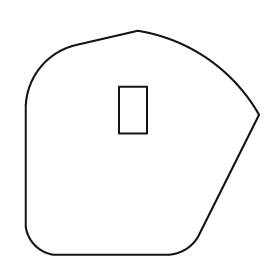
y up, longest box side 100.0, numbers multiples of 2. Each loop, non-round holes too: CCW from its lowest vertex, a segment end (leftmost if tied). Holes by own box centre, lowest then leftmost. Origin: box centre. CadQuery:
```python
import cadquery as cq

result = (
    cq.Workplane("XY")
    .moveTo(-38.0, -48.0)
    .lineTo(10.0, -48.0)
    .threePointArc((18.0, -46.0), (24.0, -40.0))
    .lineTo(50.0, 12.0)
    .threePointArc((28.0, 36.0), (-2.0, 48.0))
    .lineTo(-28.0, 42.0)
    .threePointArc((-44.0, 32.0), (-50.0, 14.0))
    .lineTo(-50.0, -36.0)
    .threePointArc((-46.0, -44.0), (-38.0, -48.0))
    .close()
    .moveTo(-10.0, 4.0)
    .lineTo(2.0, 4.0)
    .lineTo(2.0, 24.0)
    .lineTo(-10.0, 24.0)
    .close()
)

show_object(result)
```